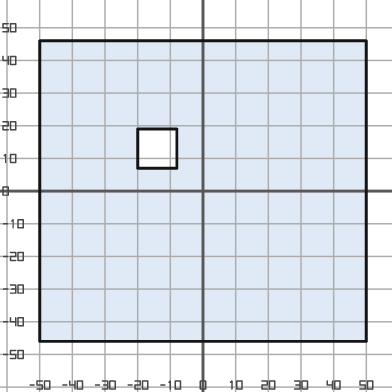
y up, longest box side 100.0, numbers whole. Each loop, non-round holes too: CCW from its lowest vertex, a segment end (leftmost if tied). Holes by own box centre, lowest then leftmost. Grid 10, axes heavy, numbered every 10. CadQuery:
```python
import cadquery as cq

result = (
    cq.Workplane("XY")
    .moveTo(-50.0, -46.0)
    .lineTo(50.0, -46.0)
    .lineTo(50.0, 46.0)
    .lineTo(-50.0, 46.0)
    .close()
    .moveTo(-20.0, 7.0)
    .lineTo(-8.0, 7.0)
    .lineTo(-8.0, 19.0)
    .lineTo(-20.0, 19.0)
    .close()
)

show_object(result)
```